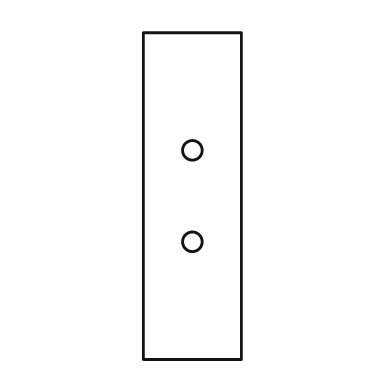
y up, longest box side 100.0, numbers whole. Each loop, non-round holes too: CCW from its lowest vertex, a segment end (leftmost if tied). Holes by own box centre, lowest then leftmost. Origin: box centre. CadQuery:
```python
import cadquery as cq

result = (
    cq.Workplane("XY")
    .moveTo(-15.0, -50.0)
    .lineTo(15.0, -50.0)
    .lineTo(15.0, 50.0)
    .lineTo(-15.0, 50.0)
    .close()
    .moveTo(0.0, -14.0)
    .circle(3.0)
    .moveTo(0.0, 14.0)
    .circle(3.0)
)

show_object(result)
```